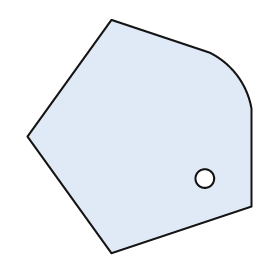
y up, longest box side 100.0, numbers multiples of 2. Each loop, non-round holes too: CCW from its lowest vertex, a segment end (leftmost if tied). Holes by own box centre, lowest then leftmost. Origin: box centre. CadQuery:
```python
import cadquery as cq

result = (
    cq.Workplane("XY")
    .moveTo(-12.0, -50.0)
    .lineTo(48.0, -30.0)
    .lineTo(48.0, 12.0)
    .threePointArc((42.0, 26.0), (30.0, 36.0))
    .lineTo(-12.0, 50.0)
    .lineTo(-48.0, 0.0)
    .close()
    .moveTo(28.0, -18.0)
    .circle(4.0)
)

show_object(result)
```